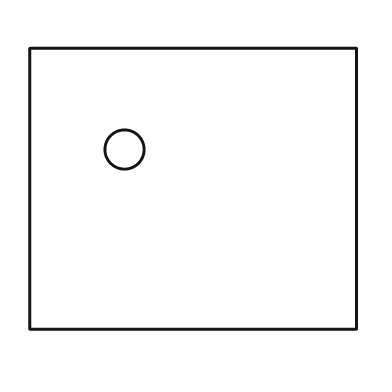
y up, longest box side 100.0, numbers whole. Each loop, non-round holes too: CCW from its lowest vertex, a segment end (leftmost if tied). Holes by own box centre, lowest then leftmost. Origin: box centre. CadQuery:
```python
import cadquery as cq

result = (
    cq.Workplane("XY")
    .moveTo(-50.0, -43.0)
    .lineTo(50.0, -43.0)
    .lineTo(50.0, 43.0)
    .lineTo(-50.0, 43.0)
    .close()
    .moveTo(-21.0, 12.0)
    .circle(6.0)
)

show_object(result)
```